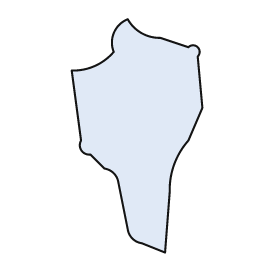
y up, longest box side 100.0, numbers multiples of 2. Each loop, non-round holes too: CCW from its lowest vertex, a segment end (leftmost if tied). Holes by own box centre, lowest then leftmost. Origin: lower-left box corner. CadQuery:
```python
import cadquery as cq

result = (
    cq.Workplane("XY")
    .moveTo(40.0, 0.0)
    .lineTo(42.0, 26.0)
    .threePointArc((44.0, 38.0), (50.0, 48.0))
    .lineTo(56.0, 62.0)
    .lineTo(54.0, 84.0)
    .threePointArc((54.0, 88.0), (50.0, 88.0))
    .lineTo(38.0, 92.0)
    .threePointArc((30.0, 94.0), (24.0, 100.0))
    .threePointArc((18.0, 94.0), (18.0, 86.0))
    .threePointArc((10.0, 80.0), (0.0, 78.0))
    .lineTo(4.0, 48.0)
    .threePointArc((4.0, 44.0), (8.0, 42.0))
    .lineTo(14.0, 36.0)
    .threePointArc((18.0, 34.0), (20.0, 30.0))
    .lineTo(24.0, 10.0)
    .threePointArc((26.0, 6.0), (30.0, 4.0))
    .close()
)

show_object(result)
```